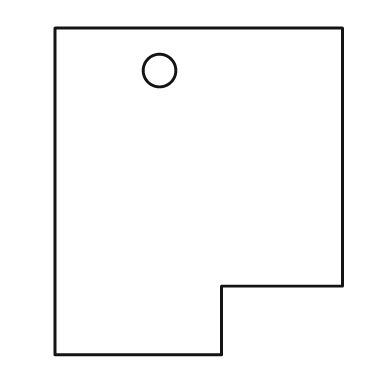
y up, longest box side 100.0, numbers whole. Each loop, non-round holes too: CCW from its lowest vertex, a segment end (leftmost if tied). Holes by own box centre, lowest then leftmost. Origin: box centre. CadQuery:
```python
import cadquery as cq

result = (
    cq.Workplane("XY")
    .moveTo(-44.0, -50.0)
    .lineTo(7.0, -50.0)
    .lineTo(7.0, -29.0)
    .lineTo(44.0, -29.0)
    .lineTo(44.0, 50.0)
    .lineTo(-44.0, 50.0)
    .close()
    .moveTo(-12.0, 37.0)
    .circle(5.0)
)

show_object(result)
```